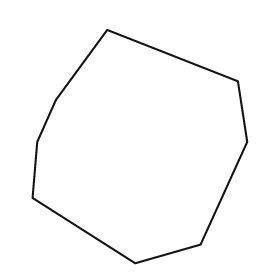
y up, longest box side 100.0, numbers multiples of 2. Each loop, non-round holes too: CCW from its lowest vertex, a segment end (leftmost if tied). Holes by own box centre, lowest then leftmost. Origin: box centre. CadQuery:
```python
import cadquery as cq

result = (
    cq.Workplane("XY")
    .moveTo(-2.0, -50.0)
    .lineTo(26.0, -42.0)
    .lineTo(46.0, 2.0)
    .lineTo(42.0, 28.0)
    .lineTo(-14.0, 50.0)
    .lineTo(-36.0, 20.0)
    .lineTo(-44.0, 2.0)
    .lineTo(-46.0, -22.0)
    .close()
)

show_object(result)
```